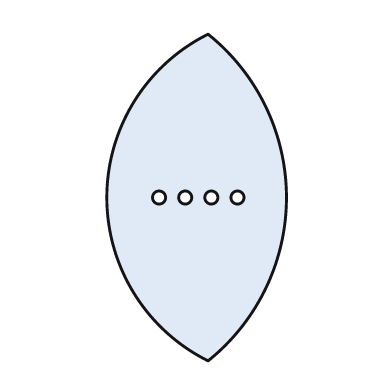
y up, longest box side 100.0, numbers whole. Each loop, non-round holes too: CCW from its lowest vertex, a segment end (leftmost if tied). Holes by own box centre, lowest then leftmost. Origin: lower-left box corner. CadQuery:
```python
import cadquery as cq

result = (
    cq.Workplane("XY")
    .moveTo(31.0, 0.0)
    .threePointArc((55.0, 50.0), (31.0, 100.0))
    .threePointArc((0.0, 50.0), (31.0, 0.0))
    .close()
    .moveTo(16.0, 50.0)
    .circle(2.0)
    .moveTo(24.0, 50.0)
    .circle(2.0)
    .moveTo(32.0, 50.0)
    .circle(2.0)
    .moveTo(40.0, 50.0)
    .circle(2.0)
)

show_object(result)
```